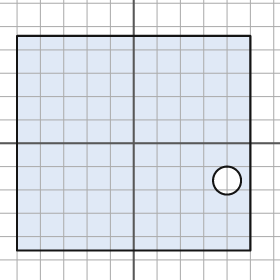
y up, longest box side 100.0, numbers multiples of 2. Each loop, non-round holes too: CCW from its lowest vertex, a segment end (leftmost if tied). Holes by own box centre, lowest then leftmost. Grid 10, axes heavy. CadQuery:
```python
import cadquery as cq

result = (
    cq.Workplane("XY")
    .moveTo(-50.0, -46.0)
    .lineTo(50.0, -46.0)
    .lineTo(50.0, 46.0)
    .lineTo(-50.0, 46.0)
    .close()
    .moveTo(40.0, -16.0)
    .circle(6.0)
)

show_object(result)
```